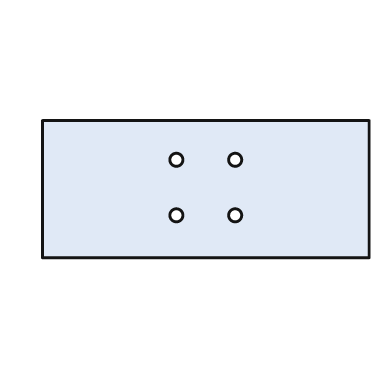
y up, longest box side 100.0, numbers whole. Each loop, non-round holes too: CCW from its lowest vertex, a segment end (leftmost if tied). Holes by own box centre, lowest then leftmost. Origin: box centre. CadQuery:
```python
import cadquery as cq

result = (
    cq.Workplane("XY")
    .moveTo(-50.0, -21.0)
    .lineTo(50.0, -21.0)
    .lineTo(50.0, 21.0)
    .lineTo(-50.0, 21.0)
    .close()
    .moveTo(-9.0, -8.0)
    .circle(2.0)
    .moveTo(9.0, -8.0)
    .circle(2.0)
    .moveTo(-9.0, 9.0)
    .circle(2.0)
    .moveTo(9.0, 9.0)
    .circle(2.0)
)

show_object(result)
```